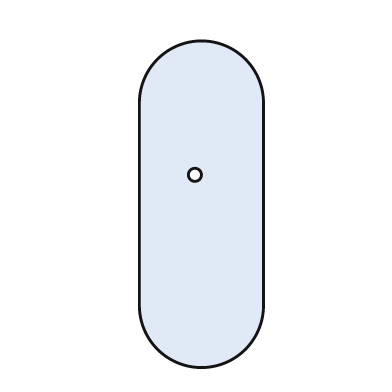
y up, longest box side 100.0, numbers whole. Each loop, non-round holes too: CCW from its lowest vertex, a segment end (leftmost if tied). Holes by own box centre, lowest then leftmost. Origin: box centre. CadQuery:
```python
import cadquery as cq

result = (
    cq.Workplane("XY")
    .moveTo(-19.0, -31.0)
    .threePointArc((0.0, -50.0), (19.0, -31.0))
    .lineTo(19.0, 31.0)
    .threePointArc((0.0, 50.0), (-19.0, 31.0))
    .close()
    .moveTo(-2.0, 9.0)
    .circle(2.0)
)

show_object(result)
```